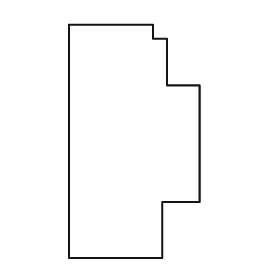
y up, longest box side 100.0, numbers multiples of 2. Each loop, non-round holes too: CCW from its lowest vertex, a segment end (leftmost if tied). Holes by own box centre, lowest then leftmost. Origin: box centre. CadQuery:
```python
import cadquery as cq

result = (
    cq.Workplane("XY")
    .moveTo(-28.0, -50.0)
    .lineTo(12.0, -50.0)
    .lineTo(12.0, -26.0)
    .lineTo(28.0, -26.0)
    .lineTo(28.0, 24.0)
    .lineTo(14.0, 24.0)
    .lineTo(14.0, 44.0)
    .lineTo(8.0, 44.0)
    .lineTo(8.0, 50.0)
    .lineTo(-28.0, 50.0)
    .close()
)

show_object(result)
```